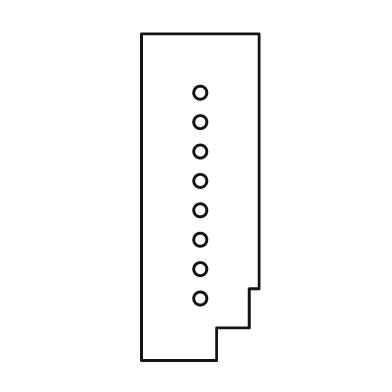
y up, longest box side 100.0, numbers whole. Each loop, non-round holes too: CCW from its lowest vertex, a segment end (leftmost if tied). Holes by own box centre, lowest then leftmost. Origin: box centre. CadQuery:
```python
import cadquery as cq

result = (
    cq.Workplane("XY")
    .moveTo(-18.0, -50.0)
    .lineTo(5.0, -50.0)
    .lineTo(5.0, -40.0)
    .lineTo(15.0, -40.0)
    .lineTo(15.0, -28.0)
    .lineTo(18.0, -28.0)
    .lineTo(18.0, 50.0)
    .lineTo(-18.0, 50.0)
    .close()
    .moveTo(0.0, -31.0)
    .circle(2.0)
    .moveTo(0.0, -22.0)
    .circle(2.0)
    .moveTo(0.0, -13.0)
    .circle(2.0)
    .moveTo(0.0, -4.0)
    .circle(2.0)
    .moveTo(0.0, 5.0)
    .circle(2.0)
    .moveTo(0.0, 14.0)
    .circle(2.0)
    .moveTo(0.0, 23.0)
    .circle(2.0)
    .moveTo(0.0, 32.0)
    .circle(2.0)
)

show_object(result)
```